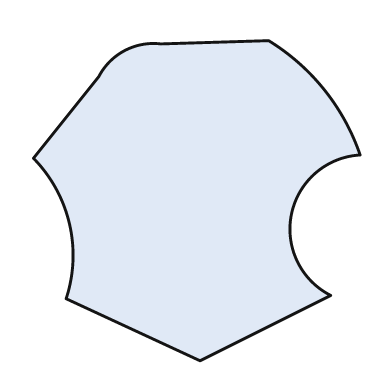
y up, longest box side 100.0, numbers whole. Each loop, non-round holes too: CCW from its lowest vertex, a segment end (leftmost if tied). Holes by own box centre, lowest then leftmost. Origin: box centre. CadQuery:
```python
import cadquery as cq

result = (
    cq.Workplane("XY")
    .moveTo(1.0, -49.0)
    .lineTo(41.0, -29.0)
    .threePointArc((29.0, -4.0), (50.0, 14.0))
    .threePointArc((39.0, 34.0), (22.0, 49.0))
    .lineTo(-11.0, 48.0)
    .threePointArc((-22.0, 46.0), (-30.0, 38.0))
    .lineTo(-50.0, 13.0)
    .threePointArc((-39.0, -7.0), (-40.0, -30.0))
    .close()
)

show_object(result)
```